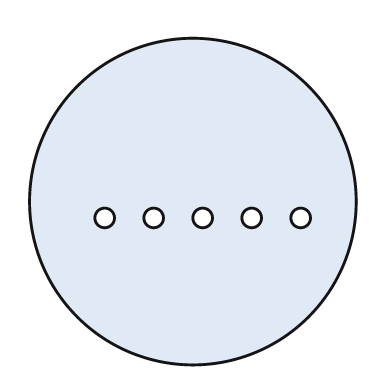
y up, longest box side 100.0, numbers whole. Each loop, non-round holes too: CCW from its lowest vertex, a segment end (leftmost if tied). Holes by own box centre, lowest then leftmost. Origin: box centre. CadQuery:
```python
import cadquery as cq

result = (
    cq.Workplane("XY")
    .moveTo(0.0, 0.0)
    .circle(50.0)
    .moveTo(-27.0, -5.0)
    .circle(3.0)
    .moveTo(-12.0, -5.0)
    .circle(3.0)
    .moveTo(3.0, -5.0)
    .circle(3.0)
    .moveTo(18.0, -5.0)
    .circle(3.0)
    .moveTo(33.0, -5.0)
    .circle(3.0)
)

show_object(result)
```